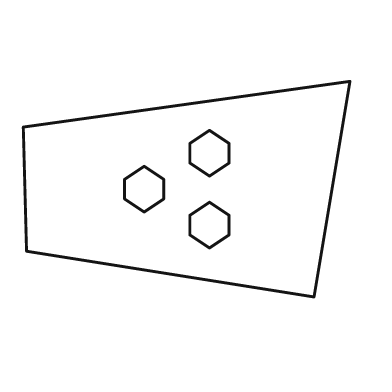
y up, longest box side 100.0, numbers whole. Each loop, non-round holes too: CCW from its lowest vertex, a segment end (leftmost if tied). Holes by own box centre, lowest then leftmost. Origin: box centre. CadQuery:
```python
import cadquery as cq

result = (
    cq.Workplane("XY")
    .moveTo(39.0, -33.0)
    .lineTo(50.0, 33.0)
    .lineTo(-50.0, 19.0)
    .lineTo(-49.0, -19.0)
    .close()
    .moveTo(7.0, -18.0)
    .lineTo(13.0, -14.0)
    .lineTo(13.0, -8.0)
    .lineTo(7.0, -4.0)
    .lineTo(1.0, -8.0)
    .lineTo(1.0, -14.0)
    .close()
    .moveTo(-13.0, -7.0)
    .lineTo(-7.0, -3.0)
    .lineTo(-7.0, 3.0)
    .lineTo(-13.0, 7.0)
    .lineTo(-19.0, 3.0)
    .lineTo(-19.0, -3.0)
    .close()
    .moveTo(7.0, 4.0)
    .lineTo(13.0, 8.0)
    .lineTo(13.0, 14.0)
    .lineTo(7.0, 18.0)
    .lineTo(1.0, 14.0)
    .lineTo(1.0, 8.0)
    .close()
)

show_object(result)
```